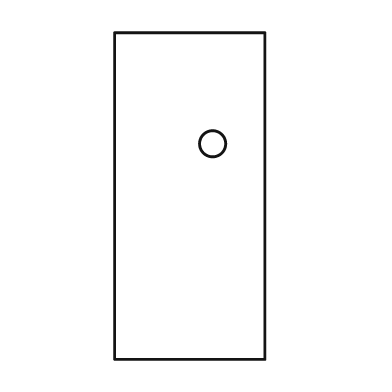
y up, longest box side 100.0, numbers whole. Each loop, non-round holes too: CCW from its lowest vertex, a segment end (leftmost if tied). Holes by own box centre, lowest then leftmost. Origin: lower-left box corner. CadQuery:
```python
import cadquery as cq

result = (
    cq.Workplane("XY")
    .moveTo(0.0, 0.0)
    .lineTo(46.0, 0.0)
    .lineTo(46.0, 100.0)
    .lineTo(0.0, 100.0)
    .close()
    .moveTo(30.0, 66.0)
    .circle(4.0)
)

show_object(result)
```